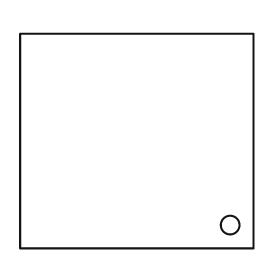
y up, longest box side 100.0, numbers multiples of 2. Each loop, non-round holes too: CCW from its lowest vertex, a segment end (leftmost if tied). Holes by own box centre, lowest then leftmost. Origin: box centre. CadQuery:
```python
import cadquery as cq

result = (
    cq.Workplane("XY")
    .moveTo(-50.0, -46.0)
    .lineTo(50.0, -46.0)
    .lineTo(50.0, 46.0)
    .lineTo(-50.0, 46.0)
    .close()
    .moveTo(40.0, -36.0)
    .circle(4.0)
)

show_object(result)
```